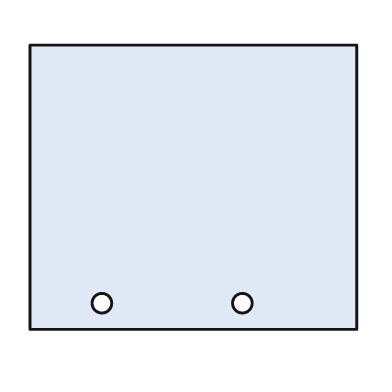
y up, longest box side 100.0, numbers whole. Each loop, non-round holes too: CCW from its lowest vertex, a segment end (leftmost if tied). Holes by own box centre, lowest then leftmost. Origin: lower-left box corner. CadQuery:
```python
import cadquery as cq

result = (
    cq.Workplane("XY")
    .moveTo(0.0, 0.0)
    .lineTo(100.0, 0.0)
    .lineTo(100.0, 87.0)
    .lineTo(0.0, 87.0)
    .close()
    .moveTo(22.0, 8.0)
    .circle(3.0)
    .moveTo(65.0, 8.0)
    .circle(3.0)
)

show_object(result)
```